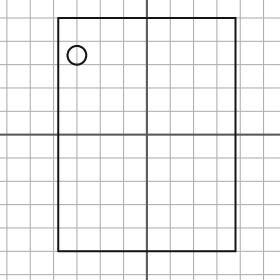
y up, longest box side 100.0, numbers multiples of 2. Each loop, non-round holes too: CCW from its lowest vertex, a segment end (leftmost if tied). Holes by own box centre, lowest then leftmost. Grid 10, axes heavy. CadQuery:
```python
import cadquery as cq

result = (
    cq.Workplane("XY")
    .moveTo(-38.0, -50.0)
    .lineTo(38.0, -50.0)
    .lineTo(38.0, 50.0)
    .lineTo(-38.0, 50.0)
    .close()
    .moveTo(-30.0, 34.0)
    .circle(4.0)
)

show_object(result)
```